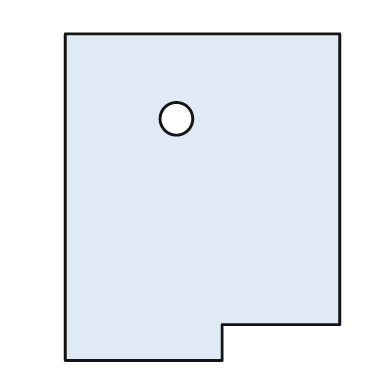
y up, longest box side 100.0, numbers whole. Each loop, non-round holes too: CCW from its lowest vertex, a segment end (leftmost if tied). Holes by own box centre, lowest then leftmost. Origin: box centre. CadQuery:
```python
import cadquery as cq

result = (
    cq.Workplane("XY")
    .moveTo(-42.0, -50.0)
    .lineTo(6.0, -50.0)
    .lineTo(6.0, -39.0)
    .lineTo(42.0, -39.0)
    .lineTo(42.0, 50.0)
    .lineTo(-42.0, 50.0)
    .close()
    .moveTo(-8.0, 24.0)
    .circle(5.0)
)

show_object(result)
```